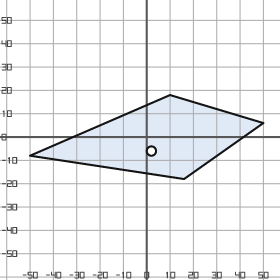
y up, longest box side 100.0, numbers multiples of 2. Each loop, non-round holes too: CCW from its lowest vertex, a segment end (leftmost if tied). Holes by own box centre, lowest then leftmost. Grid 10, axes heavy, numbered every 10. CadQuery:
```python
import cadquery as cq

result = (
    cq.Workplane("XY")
    .moveTo(16.0, -18.0)
    .lineTo(50.0, 6.0)
    .lineTo(10.0, 18.0)
    .lineTo(-50.0, -8.0)
    .close()
    .moveTo(2.0, -6.0)
    .circle(2.0)
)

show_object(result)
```